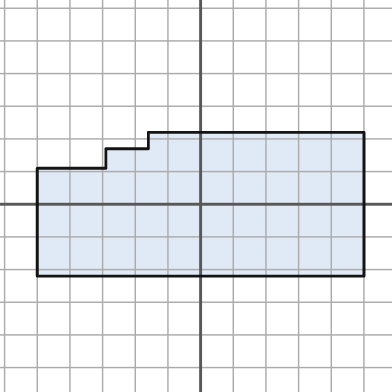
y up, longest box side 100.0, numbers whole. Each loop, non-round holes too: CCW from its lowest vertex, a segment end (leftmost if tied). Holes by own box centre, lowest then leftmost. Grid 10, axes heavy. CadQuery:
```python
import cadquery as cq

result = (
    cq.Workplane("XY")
    .moveTo(-50.0, -22.0)
    .lineTo(50.0, -22.0)
    .lineTo(50.0, 22.0)
    .lineTo(-16.0, 22.0)
    .lineTo(-16.0, 17.0)
    .lineTo(-29.0, 17.0)
    .lineTo(-29.0, 11.0)
    .lineTo(-50.0, 11.0)
    .close()
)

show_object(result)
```